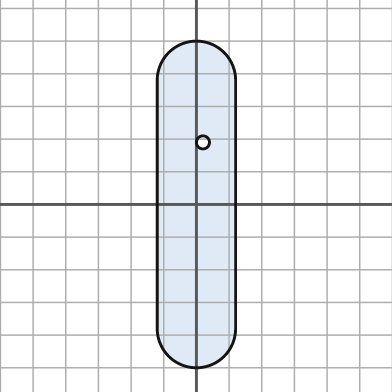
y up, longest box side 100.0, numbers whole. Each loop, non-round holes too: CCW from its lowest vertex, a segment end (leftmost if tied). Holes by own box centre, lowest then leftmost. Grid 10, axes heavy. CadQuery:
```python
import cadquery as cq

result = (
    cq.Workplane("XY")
    .moveTo(-12.0, -38.0)
    .threePointArc((0.0, -50.0), (12.0, -38.0))
    .lineTo(12.0, 38.0)
    .threePointArc((0.0, 50.0), (-12.0, 38.0))
    .close()
    .moveTo(2.0, 19.0)
    .circle(2.0)
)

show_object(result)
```